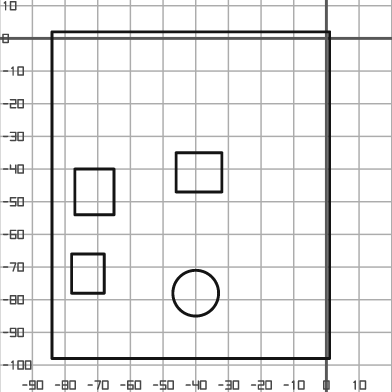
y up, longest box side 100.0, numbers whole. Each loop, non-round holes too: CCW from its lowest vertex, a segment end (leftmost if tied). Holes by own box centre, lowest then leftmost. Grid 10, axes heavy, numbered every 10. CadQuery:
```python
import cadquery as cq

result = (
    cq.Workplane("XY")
    .moveTo(-84.0, -98.0)
    .lineTo(1.0, -98.0)
    .lineTo(1.0, 2.0)
    .lineTo(-84.0, 2.0)
    .close()
    .moveTo(-40.0, -78.0)
    .circle(7.0)
    .moveTo(-78.0, -78.0)
    .lineTo(-68.0, -78.0)
    .lineTo(-68.0, -66.0)
    .lineTo(-78.0, -66.0)
    .close()
    .moveTo(-77.0, -54.0)
    .lineTo(-65.0, -54.0)
    .lineTo(-65.0, -40.0)
    .lineTo(-77.0, -40.0)
    .close()
    .moveTo(-46.0, -47.0)
    .lineTo(-32.0, -47.0)
    .lineTo(-32.0, -35.0)
    .lineTo(-46.0, -35.0)
    .close()
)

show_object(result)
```